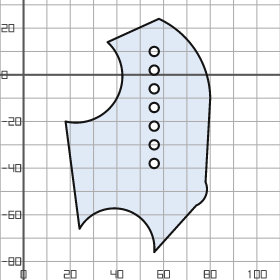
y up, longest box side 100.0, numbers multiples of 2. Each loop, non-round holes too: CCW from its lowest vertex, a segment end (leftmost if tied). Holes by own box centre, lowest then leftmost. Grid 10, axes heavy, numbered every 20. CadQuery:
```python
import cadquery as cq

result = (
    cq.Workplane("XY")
    .moveTo(56.0, -76.0)
    .lineTo(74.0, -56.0)
    .threePointArc((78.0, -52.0), (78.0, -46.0))
    .lineTo(80.0, -10.0)
    .threePointArc((74.0, 10.0), (58.0, 24.0))
    .lineTo(36.0, 14.0)
    .threePointArc((40.0, -10.0), (18.0, -20.0))
    .lineTo(24.0, -66.0)
    .threePointArc((44.0, -58.0), (56.0, -76.0))
    .close()
    .moveTo(56.0, -38.0)
    .circle(2.0)
    .moveTo(56.0, -30.0)
    .circle(2.0)
    .moveTo(56.0, -22.0)
    .circle(2.0)
    .moveTo(56.0, -14.0)
    .circle(2.0)
    .moveTo(56.0, -6.0)
    .circle(2.0)
    .moveTo(56.0, 2.0)
    .circle(2.0)
    .moveTo(56.0, 10.0)
    .circle(2.0)
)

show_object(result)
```